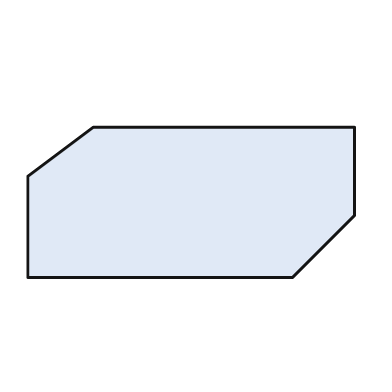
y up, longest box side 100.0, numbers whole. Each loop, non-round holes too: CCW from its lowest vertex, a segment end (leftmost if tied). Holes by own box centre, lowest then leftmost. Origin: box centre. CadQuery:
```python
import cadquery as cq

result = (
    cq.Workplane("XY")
    .moveTo(-50.0, -23.0)
    .lineTo(31.0, -23.0)
    .lineTo(50.0, -4.0)
    .lineTo(50.0, 23.0)
    .lineTo(-30.0, 23.0)
    .lineTo(-50.0, 8.0)
    .close()
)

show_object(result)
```